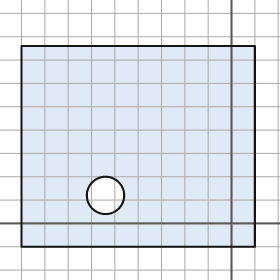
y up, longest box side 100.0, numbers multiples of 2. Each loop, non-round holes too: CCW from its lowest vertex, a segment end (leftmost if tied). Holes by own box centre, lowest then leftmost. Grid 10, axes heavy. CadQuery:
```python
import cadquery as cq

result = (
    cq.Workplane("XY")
    .moveTo(-90.0, -10.0)
    .lineTo(10.0, -10.0)
    .lineTo(10.0, 76.0)
    .lineTo(-90.0, 76.0)
    .close()
    .moveTo(-54.0, 12.0)
    .circle(8.0)
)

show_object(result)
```